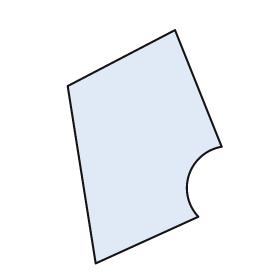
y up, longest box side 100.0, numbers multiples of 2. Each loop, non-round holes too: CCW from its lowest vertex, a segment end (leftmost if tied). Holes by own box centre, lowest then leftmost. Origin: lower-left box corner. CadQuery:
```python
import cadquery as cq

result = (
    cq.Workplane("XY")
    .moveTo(12.0, 0.0)
    .lineTo(56.0, 20.0)
    .threePointArc((52.0, 38.0), (66.0, 50.0))
    .lineTo(46.0, 100.0)
    .lineTo(0.0, 76.0)
    .close()
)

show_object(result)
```